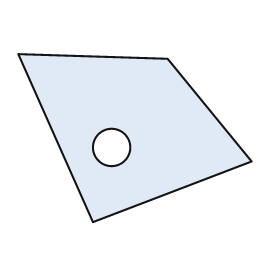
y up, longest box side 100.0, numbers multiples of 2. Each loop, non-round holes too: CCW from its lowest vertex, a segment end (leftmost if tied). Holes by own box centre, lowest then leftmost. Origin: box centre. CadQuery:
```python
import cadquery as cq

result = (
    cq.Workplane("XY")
    .moveTo(-18.0, -36.0)
    .lineTo(50.0, -10.0)
    .lineTo(14.0, 34.0)
    .lineTo(-50.0, 36.0)
    .close()
    .moveTo(-10.0, -4.0)
    .circle(8.0)
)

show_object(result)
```